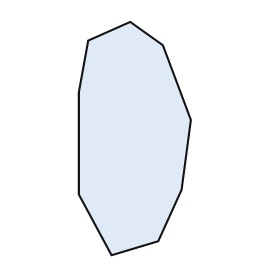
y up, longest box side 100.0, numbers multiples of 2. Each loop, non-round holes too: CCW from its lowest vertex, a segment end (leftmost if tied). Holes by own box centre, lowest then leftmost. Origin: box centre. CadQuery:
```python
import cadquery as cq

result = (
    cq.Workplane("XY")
    .moveTo(-10.0, -50.0)
    .lineTo(10.0, -44.0)
    .lineTo(20.0, -22.0)
    .lineTo(24.0, 8.0)
    .lineTo(12.0, 40.0)
    .lineTo(-2.0, 50.0)
    .lineTo(-20.0, 42.0)
    .lineTo(-24.0, 20.0)
    .lineTo(-24.0, -24.0)
    .close()
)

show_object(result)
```